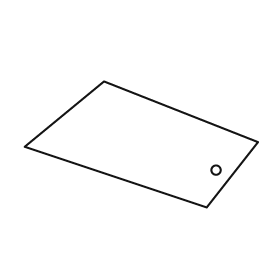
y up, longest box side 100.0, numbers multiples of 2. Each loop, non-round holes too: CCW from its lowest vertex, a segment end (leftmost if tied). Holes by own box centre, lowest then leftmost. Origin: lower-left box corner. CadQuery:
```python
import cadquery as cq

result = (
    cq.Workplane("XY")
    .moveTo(78.0, 0.0)
    .lineTo(100.0, 28.0)
    .lineTo(34.0, 54.0)
    .lineTo(0.0, 26.0)
    .close()
    .moveTo(82.0, 16.0)
    .circle(2.0)
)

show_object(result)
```